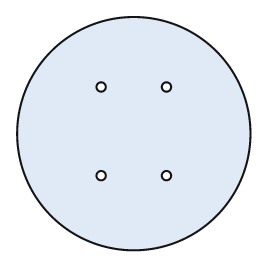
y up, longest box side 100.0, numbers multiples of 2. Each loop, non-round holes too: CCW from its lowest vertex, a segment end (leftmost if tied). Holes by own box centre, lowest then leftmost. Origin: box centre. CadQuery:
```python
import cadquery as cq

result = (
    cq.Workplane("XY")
    .moveTo(0.0, 0.0)
    .circle(50.0)
    .moveTo(-14.0, -18.0)
    .circle(2.0)
    .moveTo(14.0, -18.0)
    .circle(2.0)
    .moveTo(-14.0, 20.0)
    .circle(2.0)
    .moveTo(14.0, 20.0)
    .circle(2.0)
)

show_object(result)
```